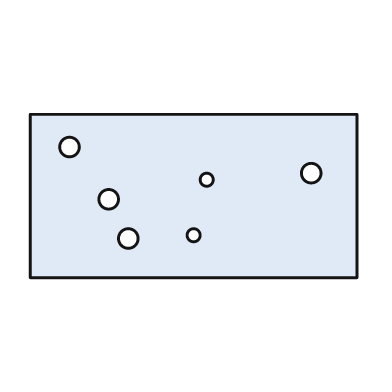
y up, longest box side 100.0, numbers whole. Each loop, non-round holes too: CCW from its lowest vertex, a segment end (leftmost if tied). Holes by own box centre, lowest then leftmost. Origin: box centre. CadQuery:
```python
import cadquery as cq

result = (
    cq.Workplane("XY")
    .moveTo(-50.0, -25.0)
    .lineTo(50.0, -25.0)
    .lineTo(50.0, 25.0)
    .lineTo(-50.0, 25.0)
    .close()
    .moveTo(-20.0, -13.0)
    .circle(3.0)
    .moveTo(0.0, -12.0)
    .circle(2.0)
    .moveTo(-26.0, -1.0)
    .circle(3.0)
    .moveTo(4.0, 5.0)
    .circle(2.0)
    .moveTo(36.0, 7.0)
    .circle(3.0)
    .moveTo(-38.0, 15.0)
    .circle(3.0)
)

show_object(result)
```